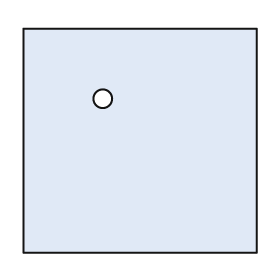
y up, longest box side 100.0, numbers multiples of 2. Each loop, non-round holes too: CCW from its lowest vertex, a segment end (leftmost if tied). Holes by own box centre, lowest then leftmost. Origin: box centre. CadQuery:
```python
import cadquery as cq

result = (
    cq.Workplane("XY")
    .moveTo(-50.0, -48.0)
    .lineTo(50.0, -48.0)
    .lineTo(50.0, 48.0)
    .lineTo(-50.0, 48.0)
    .close()
    .moveTo(-16.0, 18.0)
    .circle(4.0)
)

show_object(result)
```